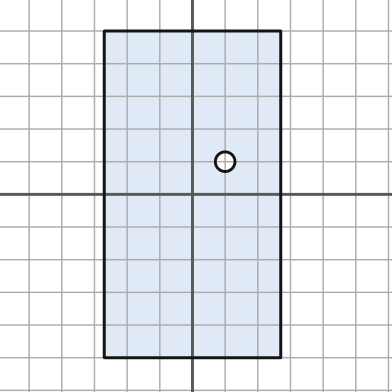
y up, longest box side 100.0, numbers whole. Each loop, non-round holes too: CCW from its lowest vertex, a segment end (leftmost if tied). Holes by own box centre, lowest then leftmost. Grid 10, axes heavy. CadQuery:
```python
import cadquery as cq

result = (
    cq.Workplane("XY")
    .moveTo(-27.0, -50.0)
    .lineTo(27.0, -50.0)
    .lineTo(27.0, 50.0)
    .lineTo(-27.0, 50.0)
    .close()
    .moveTo(10.0, 10.0)
    .circle(3.0)
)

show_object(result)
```